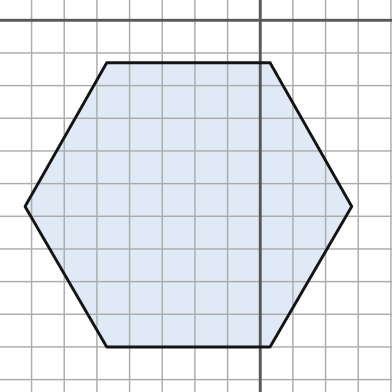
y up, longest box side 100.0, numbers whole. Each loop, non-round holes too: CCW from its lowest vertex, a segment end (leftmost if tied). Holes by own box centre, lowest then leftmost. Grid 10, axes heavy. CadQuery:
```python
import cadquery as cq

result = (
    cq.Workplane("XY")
    .moveTo(-47.0, -100.0)
    .lineTo(3.0, -100.0)
    .lineTo(28.0, -57.0)
    .lineTo(3.0, -13.0)
    .lineTo(-47.0, -13.0)
    .lineTo(-72.0, -57.0)
    .close()
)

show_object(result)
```